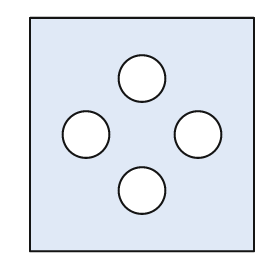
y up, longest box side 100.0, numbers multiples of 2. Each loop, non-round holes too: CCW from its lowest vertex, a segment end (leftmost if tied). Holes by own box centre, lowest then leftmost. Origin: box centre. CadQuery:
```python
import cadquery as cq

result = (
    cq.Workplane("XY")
    .moveTo(-48.0, -50.0)
    .lineTo(48.0, -50.0)
    .lineTo(48.0, 50.0)
    .lineTo(-48.0, 50.0)
    .close()
    .moveTo(0.0, -24.0)
    .circle(10.0)
    .moveTo(-24.0, 0.0)
    .circle(10.0)
    .moveTo(24.0, 0.0)
    .circle(10.0)
    .moveTo(0.0, 24.0)
    .circle(10.0)
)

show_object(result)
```